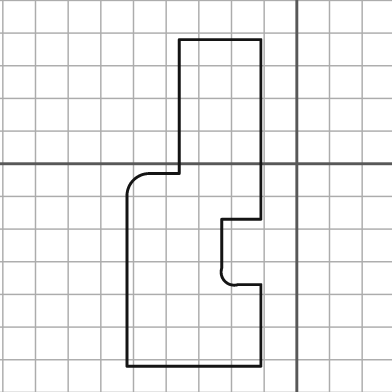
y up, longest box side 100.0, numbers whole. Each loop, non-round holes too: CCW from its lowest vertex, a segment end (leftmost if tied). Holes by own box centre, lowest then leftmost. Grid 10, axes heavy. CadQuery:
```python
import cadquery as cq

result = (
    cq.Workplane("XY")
    .moveTo(-52.0, -62.0)
    .lineTo(-11.0, -62.0)
    .lineTo(-11.0, -37.0)
    .lineTo(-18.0, -37.0)
    .threePointArc((-22.0, -36.0), (-23.0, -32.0))
    .lineTo(-23.0, -17.0)
    .lineTo(-11.0, -17.0)
    .lineTo(-11.0, 38.0)
    .lineTo(-36.0, 38.0)
    .lineTo(-36.0, -3.0)
    .lineTo(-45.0, -3.0)
    .threePointArc((-50.0, -5.0), (-52.0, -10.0))
    .close()
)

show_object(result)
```